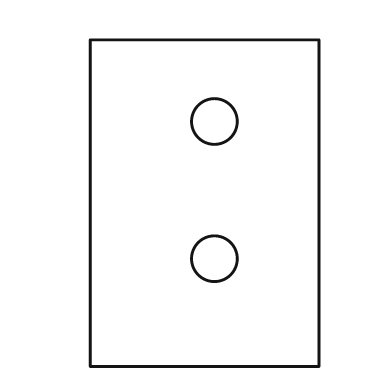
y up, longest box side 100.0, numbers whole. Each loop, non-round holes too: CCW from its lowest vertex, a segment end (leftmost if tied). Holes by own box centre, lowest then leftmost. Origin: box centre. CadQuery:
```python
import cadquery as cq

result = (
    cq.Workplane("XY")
    .moveTo(-35.0, -50.0)
    .lineTo(35.0, -50.0)
    .lineTo(35.0, 50.0)
    .lineTo(-35.0, 50.0)
    .close()
    .moveTo(3.0, -17.0)
    .circle(7.0)
    .moveTo(3.0, 25.0)
    .circle(7.0)
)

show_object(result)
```